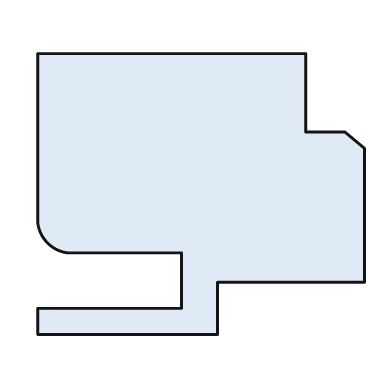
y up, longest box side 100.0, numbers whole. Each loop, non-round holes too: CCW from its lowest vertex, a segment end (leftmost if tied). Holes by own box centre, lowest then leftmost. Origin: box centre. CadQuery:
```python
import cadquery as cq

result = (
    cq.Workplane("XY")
    .moveTo(-50.0, -43.0)
    .lineTo(5.0, -43.0)
    .lineTo(5.0, -27.0)
    .lineTo(50.0, -27.0)
    .lineTo(50.0, 14.0)
    .lineTo(44.0, 19.0)
    .lineTo(32.0, 19.0)
    .lineTo(32.0, 43.0)
    .lineTo(-50.0, 43.0)
    .lineTo(-50.0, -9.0)
    .threePointArc((-47.0, -15.0), (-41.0, -18.0))
    .lineTo(-6.0, -18.0)
    .lineTo(-6.0, -35.0)
    .lineTo(-50.0, -35.0)
    .close()
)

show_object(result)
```